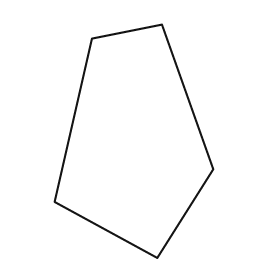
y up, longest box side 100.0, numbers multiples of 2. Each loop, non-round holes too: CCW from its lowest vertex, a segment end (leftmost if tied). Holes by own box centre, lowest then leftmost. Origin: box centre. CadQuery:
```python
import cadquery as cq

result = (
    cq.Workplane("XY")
    .moveTo(10.0, -50.0)
    .lineTo(34.0, -12.0)
    .lineTo(12.0, 50.0)
    .lineTo(-18.0, 44.0)
    .lineTo(-34.0, -26.0)
    .close()
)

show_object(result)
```